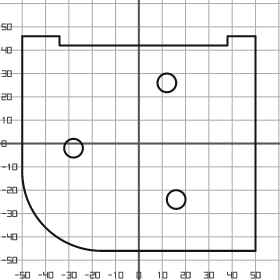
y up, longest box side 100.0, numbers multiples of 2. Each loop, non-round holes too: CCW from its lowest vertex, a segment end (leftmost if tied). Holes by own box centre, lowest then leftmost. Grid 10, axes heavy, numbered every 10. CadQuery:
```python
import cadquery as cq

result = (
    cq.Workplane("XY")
    .moveTo(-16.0, -46.0)
    .lineTo(50.0, -46.0)
    .lineTo(50.0, 46.0)
    .lineTo(38.0, 46.0)
    .lineTo(38.0, 42.0)
    .lineTo(-34.0, 42.0)
    .lineTo(-34.0, 46.0)
    .lineTo(-50.0, 46.0)
    .lineTo(-50.0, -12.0)
    .threePointArc((-40.0, -36.0), (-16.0, -46.0))
    .close()
    .moveTo(16.0, -24.0)
    .circle(4.0)
    .moveTo(-28.0, -2.0)
    .circle(4.0)
    .moveTo(12.0, 26.0)
    .circle(4.0)
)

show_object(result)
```